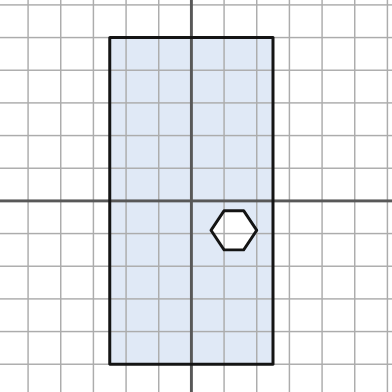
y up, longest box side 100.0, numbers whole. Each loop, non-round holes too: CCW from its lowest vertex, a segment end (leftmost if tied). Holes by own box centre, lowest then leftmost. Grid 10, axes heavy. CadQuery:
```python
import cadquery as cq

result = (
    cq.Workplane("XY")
    .moveTo(-25.0, -50.0)
    .lineTo(25.0, -50.0)
    .lineTo(25.0, 50.0)
    .lineTo(-25.0, 50.0)
    .close()
    .moveTo(10.0, -15.0)
    .lineTo(16.0, -15.0)
    .lineTo(20.0, -9.0)
    .lineTo(16.0, -3.0)
    .lineTo(10.0, -3.0)
    .lineTo(6.0, -9.0)
    .close()
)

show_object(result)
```